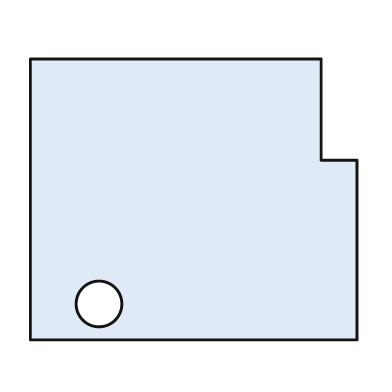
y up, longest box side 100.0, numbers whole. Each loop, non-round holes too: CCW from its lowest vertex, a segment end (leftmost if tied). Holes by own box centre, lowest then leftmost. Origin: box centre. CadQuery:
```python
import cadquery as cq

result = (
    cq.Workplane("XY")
    .moveTo(-50.0, -43.0)
    .lineTo(50.0, -43.0)
    .lineTo(50.0, 12.0)
    .lineTo(39.0, 12.0)
    .lineTo(39.0, 43.0)
    .lineTo(-50.0, 43.0)
    .close()
    .moveTo(-29.0, -32.0)
    .circle(7.0)
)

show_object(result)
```